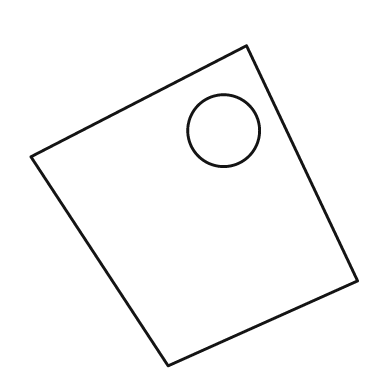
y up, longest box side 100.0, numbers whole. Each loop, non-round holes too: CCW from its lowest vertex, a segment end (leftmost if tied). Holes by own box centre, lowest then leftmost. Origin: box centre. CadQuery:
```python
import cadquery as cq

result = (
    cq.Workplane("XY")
    .moveTo(-8.0, -49.0)
    .lineTo(50.0, -23.0)
    .lineTo(16.0, 49.0)
    .lineTo(-50.0, 15.0)
    .close()
    .moveTo(9.0, 23.0)
    .circle(11.0)
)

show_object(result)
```